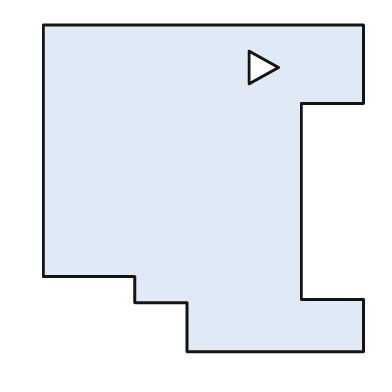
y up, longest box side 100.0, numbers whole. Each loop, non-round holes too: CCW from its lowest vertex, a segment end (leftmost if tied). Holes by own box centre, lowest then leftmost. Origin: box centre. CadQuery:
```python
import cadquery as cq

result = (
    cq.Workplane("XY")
    .moveTo(-5.0, -50.0)
    .lineTo(49.0, -50.0)
    .lineTo(49.0, -34.0)
    .lineTo(30.0, -34.0)
    .lineTo(30.0, 26.0)
    .lineTo(49.0, 26.0)
    .lineTo(49.0, 50.0)
    .lineTo(-49.0, 50.0)
    .lineTo(-49.0, -27.0)
    .lineTo(-21.0, -27.0)
    .lineTo(-21.0, -35.0)
    .lineTo(-5.0, -35.0)
    .close()
    .moveTo(14.0, 32.0)
    .lineTo(23.0, 37.0)
    .lineTo(14.0, 42.0)
    .close()
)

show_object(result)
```